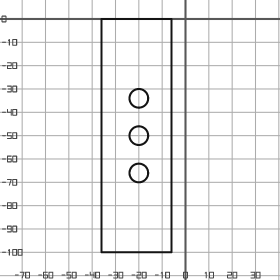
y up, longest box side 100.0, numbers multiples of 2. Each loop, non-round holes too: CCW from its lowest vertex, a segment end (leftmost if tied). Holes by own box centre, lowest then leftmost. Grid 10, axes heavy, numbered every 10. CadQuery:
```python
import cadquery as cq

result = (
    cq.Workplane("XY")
    .moveTo(-36.0, -100.0)
    .lineTo(-6.0, -100.0)
    .lineTo(-6.0, 0.0)
    .lineTo(-36.0, 0.0)
    .close()
    .moveTo(-20.0, -66.0)
    .circle(4.0)
    .moveTo(-20.0, -50.0)
    .circle(4.0)
    .moveTo(-20.0, -34.0)
    .circle(4.0)
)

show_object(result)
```